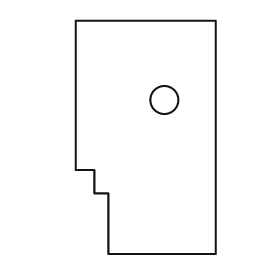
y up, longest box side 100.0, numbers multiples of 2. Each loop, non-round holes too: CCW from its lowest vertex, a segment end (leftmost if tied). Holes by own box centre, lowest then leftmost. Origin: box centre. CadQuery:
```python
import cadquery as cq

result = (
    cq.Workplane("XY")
    .moveTo(-16.0, -50.0)
    .lineTo(30.0, -50.0)
    .lineTo(30.0, 50.0)
    .lineTo(-30.0, 50.0)
    .lineTo(-30.0, -14.0)
    .lineTo(-22.0, -14.0)
    .lineTo(-22.0, -24.0)
    .lineTo(-16.0, -24.0)
    .close()
    .moveTo(8.0, 16.0)
    .circle(6.0)
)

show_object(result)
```